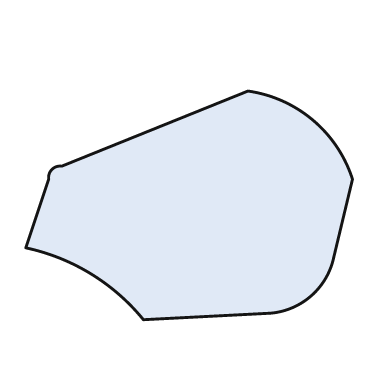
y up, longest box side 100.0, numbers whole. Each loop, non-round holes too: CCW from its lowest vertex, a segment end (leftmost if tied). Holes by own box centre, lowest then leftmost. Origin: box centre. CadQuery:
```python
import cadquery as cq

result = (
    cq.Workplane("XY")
    .moveTo(-14.0, -35.0)
    .lineTo(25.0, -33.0)
    .threePointArc((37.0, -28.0), (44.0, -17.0))
    .lineTo(50.0, 8.0)
    .threePointArc((38.0, 26.0), (18.0, 35.0))
    .lineTo(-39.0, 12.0)
    .threePointArc((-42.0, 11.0), (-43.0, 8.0))
    .lineTo(-50.0, -13.0)
    .threePointArc((-30.0, -21.0), (-14.0, -35.0))
    .close()
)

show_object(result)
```